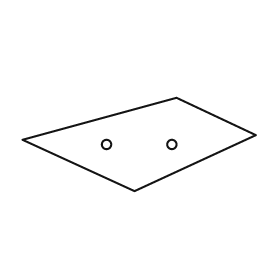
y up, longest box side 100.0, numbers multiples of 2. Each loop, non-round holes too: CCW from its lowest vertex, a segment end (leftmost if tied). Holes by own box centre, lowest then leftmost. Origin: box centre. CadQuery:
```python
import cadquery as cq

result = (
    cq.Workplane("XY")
    .moveTo(-2.0, -20.0)
    .lineTo(50.0, 4.0)
    .lineTo(16.0, 20.0)
    .lineTo(-50.0, 2.0)
    .close()
    .moveTo(-14.0, 0.0)
    .circle(2.0)
    .moveTo(14.0, 0.0)
    .circle(2.0)
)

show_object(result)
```